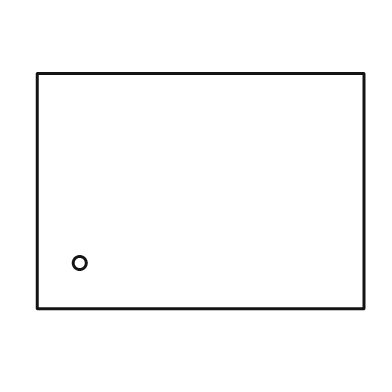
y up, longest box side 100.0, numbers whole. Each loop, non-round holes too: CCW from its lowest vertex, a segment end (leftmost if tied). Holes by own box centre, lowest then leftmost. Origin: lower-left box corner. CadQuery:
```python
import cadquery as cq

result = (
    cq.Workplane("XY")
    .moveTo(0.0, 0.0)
    .lineTo(100.0, 0.0)
    .lineTo(100.0, 72.0)
    .lineTo(0.0, 72.0)
    .close()
    .moveTo(13.0, 14.0)
    .circle(2.0)
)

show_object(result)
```